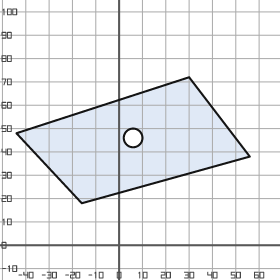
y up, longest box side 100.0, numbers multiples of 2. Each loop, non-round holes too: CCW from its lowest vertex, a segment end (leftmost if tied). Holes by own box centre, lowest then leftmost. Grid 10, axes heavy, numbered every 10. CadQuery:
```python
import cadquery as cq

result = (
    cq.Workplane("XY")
    .moveTo(-16.0, 18.0)
    .lineTo(56.0, 38.0)
    .lineTo(30.0, 72.0)
    .lineTo(-44.0, 48.0)
    .close()
    .moveTo(6.0, 46.0)
    .circle(4.0)
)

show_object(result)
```